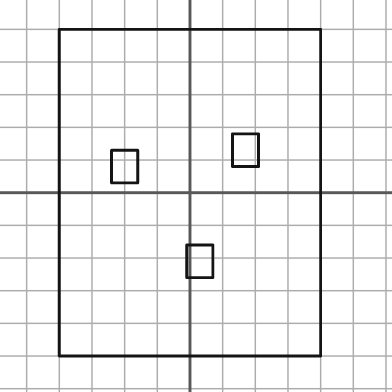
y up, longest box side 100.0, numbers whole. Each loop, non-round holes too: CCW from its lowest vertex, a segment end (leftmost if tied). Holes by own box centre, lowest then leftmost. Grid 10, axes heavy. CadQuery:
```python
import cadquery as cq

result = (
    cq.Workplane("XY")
    .moveTo(-40.0, -50.0)
    .lineTo(40.0, -50.0)
    .lineTo(40.0, 50.0)
    .lineTo(-40.0, 50.0)
    .close()
    .moveTo(-1.0, -26.0)
    .lineTo(7.0, -26.0)
    .lineTo(7.0, -16.0)
    .lineTo(-1.0, -16.0)
    .close()
    .moveTo(-24.0, 3.0)
    .lineTo(-16.0, 3.0)
    .lineTo(-16.0, 13.0)
    .lineTo(-24.0, 13.0)
    .close()
    .moveTo(13.0, 8.0)
    .lineTo(21.0, 8.0)
    .lineTo(21.0, 18.0)
    .lineTo(13.0, 18.0)
    .close()
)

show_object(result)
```